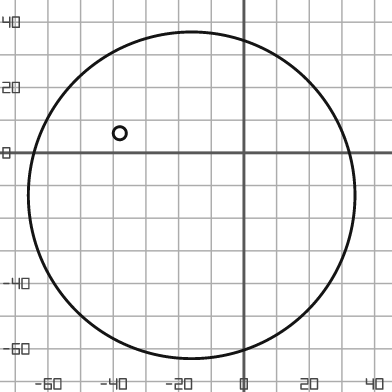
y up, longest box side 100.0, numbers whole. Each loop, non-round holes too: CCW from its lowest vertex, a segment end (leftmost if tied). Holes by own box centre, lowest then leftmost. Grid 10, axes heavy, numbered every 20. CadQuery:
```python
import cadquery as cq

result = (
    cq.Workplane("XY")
    .moveTo(-16.0, -13.0)
    .circle(50.0)
    .moveTo(-38.0, 6.0)
    .circle(2.0)
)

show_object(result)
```